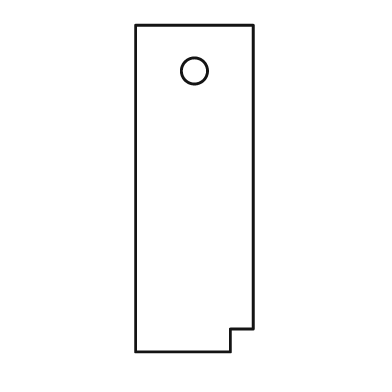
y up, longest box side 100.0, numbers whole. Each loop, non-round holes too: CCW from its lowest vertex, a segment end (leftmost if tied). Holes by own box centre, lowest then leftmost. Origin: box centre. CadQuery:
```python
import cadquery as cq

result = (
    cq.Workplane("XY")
    .moveTo(-18.0, -50.0)
    .lineTo(11.0, -50.0)
    .lineTo(11.0, -43.0)
    .lineTo(18.0, -43.0)
    .lineTo(18.0, 50.0)
    .lineTo(-18.0, 50.0)
    .close()
    .moveTo(0.0, 36.0)
    .circle(4.0)
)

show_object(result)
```